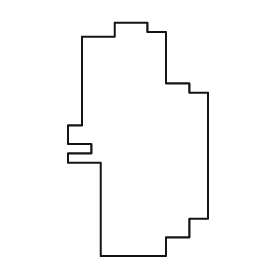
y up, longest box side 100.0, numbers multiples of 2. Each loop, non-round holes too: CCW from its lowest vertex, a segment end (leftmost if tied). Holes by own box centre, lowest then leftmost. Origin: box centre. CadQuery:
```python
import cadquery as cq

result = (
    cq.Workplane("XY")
    .moveTo(-16.0, -50.0)
    .lineTo(12.0, -50.0)
    .lineTo(12.0, -42.0)
    .lineTo(22.0, -42.0)
    .lineTo(22.0, -34.0)
    .lineTo(30.0, -34.0)
    .lineTo(30.0, 20.0)
    .lineTo(22.0, 20.0)
    .lineTo(22.0, 24.0)
    .lineTo(12.0, 24.0)
    .lineTo(12.0, 46.0)
    .lineTo(4.0, 46.0)
    .lineTo(4.0, 50.0)
    .lineTo(-10.0, 50.0)
    .lineTo(-10.0, 44.0)
    .lineTo(-24.0, 44.0)
    .lineTo(-24.0, 6.0)
    .lineTo(-30.0, 6.0)
    .lineTo(-30.0, -2.0)
    .lineTo(-20.0, -2.0)
    .lineTo(-20.0, -6.0)
    .lineTo(-30.0, -6.0)
    .lineTo(-30.0, -10.0)
    .lineTo(-16.0, -10.0)
    .close()
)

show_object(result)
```